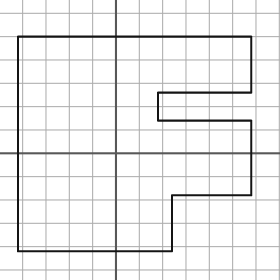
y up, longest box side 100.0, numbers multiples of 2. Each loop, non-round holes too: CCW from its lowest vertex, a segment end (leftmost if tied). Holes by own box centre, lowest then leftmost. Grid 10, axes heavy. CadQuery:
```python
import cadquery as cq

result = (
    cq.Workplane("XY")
    .moveTo(-42.0, -42.0)
    .lineTo(24.0, -42.0)
    .lineTo(24.0, -18.0)
    .lineTo(58.0, -18.0)
    .lineTo(58.0, 14.0)
    .lineTo(18.0, 14.0)
    .lineTo(18.0, 26.0)
    .lineTo(58.0, 26.0)
    .lineTo(58.0, 50.0)
    .lineTo(-42.0, 50.0)
    .close()
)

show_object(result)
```